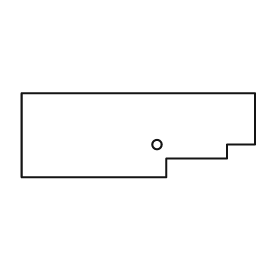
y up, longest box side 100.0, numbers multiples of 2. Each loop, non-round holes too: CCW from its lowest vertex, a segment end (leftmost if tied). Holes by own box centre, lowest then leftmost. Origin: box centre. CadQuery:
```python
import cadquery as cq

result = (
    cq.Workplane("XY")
    .moveTo(-50.0, -18.0)
    .lineTo(12.0, -18.0)
    .lineTo(12.0, -10.0)
    .lineTo(38.0, -10.0)
    .lineTo(38.0, -4.0)
    .lineTo(50.0, -4.0)
    .lineTo(50.0, 18.0)
    .lineTo(-50.0, 18.0)
    .close()
    .moveTo(8.0, -4.0)
    .circle(2.0)
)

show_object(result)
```